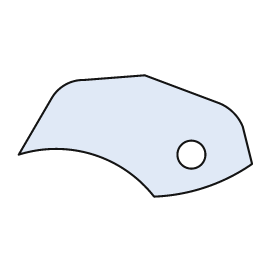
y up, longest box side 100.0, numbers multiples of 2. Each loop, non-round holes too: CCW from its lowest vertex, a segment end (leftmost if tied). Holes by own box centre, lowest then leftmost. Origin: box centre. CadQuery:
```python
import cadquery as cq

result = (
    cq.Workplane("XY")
    .moveTo(8.0, -26.0)
    .threePointArc((30.0, -22.0), (50.0, -12.0))
    .lineTo(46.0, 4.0)
    .threePointArc((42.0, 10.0), (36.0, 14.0))
    .lineTo(4.0, 26.0)
    .lineTo(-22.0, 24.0)
    .threePointArc((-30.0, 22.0), (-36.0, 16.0))
    .lineTo(-50.0, -8.0)
    .threePointArc((-18.0, -8.0), (8.0, -26.0))
    .close()
    .moveTo(24.0, -8.0)
    .circle(6.0)
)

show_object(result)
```